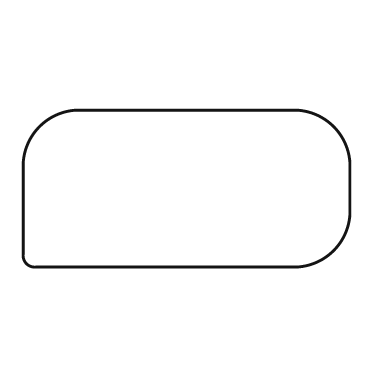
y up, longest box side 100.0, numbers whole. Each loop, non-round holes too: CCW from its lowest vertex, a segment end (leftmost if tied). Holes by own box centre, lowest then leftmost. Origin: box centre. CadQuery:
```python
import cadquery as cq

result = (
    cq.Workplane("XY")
    .moveTo(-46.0, -24.0)
    .lineTo(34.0, -24.0)
    .threePointArc((45.0, -19.0), (50.0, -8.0))
    .lineTo(50.0, 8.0)
    .threePointArc((45.0, 19.0), (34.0, 24.0))
    .lineTo(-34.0, 24.0)
    .threePointArc((-45.0, 19.0), (-50.0, 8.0))
    .lineTo(-50.0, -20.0)
    .threePointArc((-49.0, -23.0), (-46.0, -24.0))
    .close()
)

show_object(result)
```